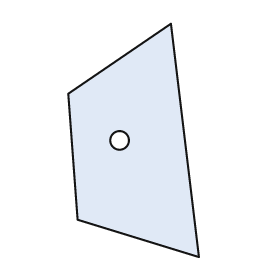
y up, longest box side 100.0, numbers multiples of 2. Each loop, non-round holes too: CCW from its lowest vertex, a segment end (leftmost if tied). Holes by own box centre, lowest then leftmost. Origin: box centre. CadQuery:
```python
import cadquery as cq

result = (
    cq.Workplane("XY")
    .moveTo(28.0, -50.0)
    .lineTo(16.0, 50.0)
    .lineTo(-28.0, 20.0)
    .lineTo(-24.0, -34.0)
    .close()
    .moveTo(-6.0, 0.0)
    .circle(4.0)
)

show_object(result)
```